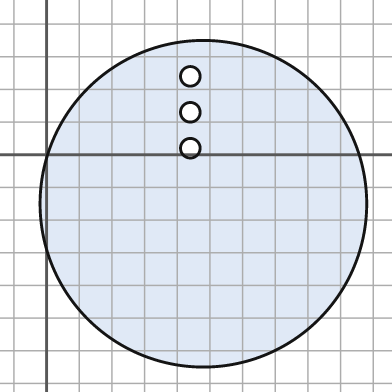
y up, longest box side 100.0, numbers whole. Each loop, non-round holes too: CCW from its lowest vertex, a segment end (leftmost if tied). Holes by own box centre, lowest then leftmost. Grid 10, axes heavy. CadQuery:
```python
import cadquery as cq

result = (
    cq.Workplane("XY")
    .moveTo(48.0, -15.0)
    .circle(50.0)
    .moveTo(44.0, 2.0)
    .circle(3.0)
    .moveTo(44.0, 13.0)
    .circle(3.0)
    .moveTo(44.0, 24.0)
    .circle(3.0)
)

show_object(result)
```